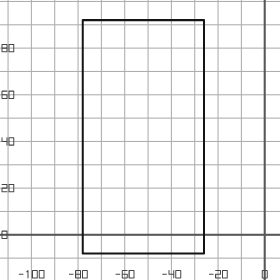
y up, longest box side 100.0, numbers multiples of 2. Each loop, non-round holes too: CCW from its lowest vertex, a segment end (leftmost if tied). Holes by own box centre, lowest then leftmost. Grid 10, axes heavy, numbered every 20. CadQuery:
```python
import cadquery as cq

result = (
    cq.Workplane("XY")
    .moveTo(-78.0, -8.0)
    .lineTo(-26.0, -8.0)
    .lineTo(-26.0, 92.0)
    .lineTo(-78.0, 92.0)
    .close()
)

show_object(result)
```